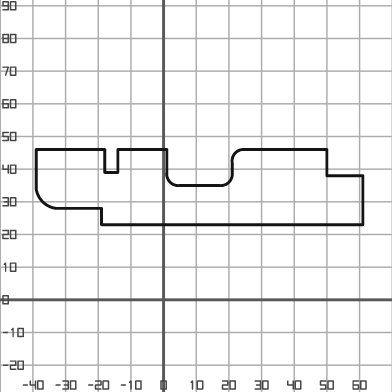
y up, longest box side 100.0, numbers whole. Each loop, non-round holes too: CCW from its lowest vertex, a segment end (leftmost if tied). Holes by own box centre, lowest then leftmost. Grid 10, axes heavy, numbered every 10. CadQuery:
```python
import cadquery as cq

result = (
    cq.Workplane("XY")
    .moveTo(-19.0, 23.0)
    .lineTo(61.0, 23.0)
    .lineTo(61.0, 38.0)
    .lineTo(50.0, 38.0)
    .lineTo(50.0, 46.0)
    .lineTo(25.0, 46.0)
    .threePointArc((22.0, 45.0), (21.0, 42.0))
    .lineTo(21.0, 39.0)
    .threePointArc((20.0, 36.0), (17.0, 35.0))
    .lineTo(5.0, 35.0)
    .threePointArc((2.0, 36.0), (1.0, 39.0))
    .lineTo(1.0, 46.0)
    .lineTo(-14.0, 46.0)
    .lineTo(-14.0, 39.0)
    .lineTo(-18.0, 39.0)
    .lineTo(-18.0, 46.0)
    .lineTo(-39.0, 46.0)
    .lineTo(-39.0, 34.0)
    .threePointArc((-37.0, 30.0), (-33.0, 28.0))
    .lineTo(-19.0, 28.0)
    .close()
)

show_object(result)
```